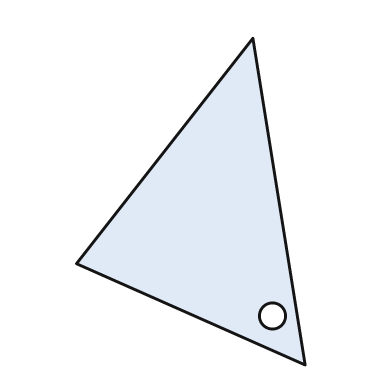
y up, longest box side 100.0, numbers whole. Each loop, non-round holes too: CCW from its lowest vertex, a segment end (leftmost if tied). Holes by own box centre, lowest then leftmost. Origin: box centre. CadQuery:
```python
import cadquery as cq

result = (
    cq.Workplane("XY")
    .moveTo(35.0, -50.0)
    .lineTo(19.0, 50.0)
    .lineTo(-35.0, -19.0)
    .close()
    .moveTo(25.0, -35.0)
    .circle(4.0)
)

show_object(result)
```